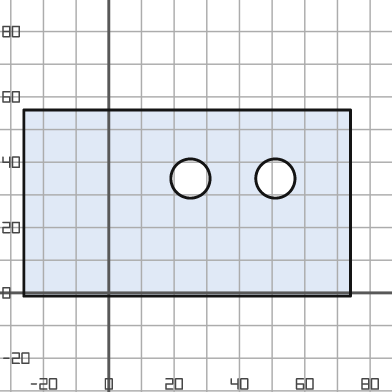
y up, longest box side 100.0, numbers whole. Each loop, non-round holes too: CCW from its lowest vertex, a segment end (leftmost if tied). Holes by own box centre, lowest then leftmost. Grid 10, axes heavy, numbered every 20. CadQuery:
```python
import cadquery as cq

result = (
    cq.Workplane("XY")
    .moveTo(-26.0, -1.0)
    .lineTo(74.0, -1.0)
    .lineTo(74.0, 56.0)
    .lineTo(-26.0, 56.0)
    .close()
    .moveTo(25.0, 35.0)
    .circle(6.0)
    .moveTo(51.0, 35.0)
    .circle(6.0)
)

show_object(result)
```